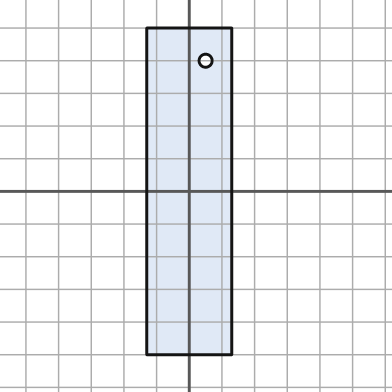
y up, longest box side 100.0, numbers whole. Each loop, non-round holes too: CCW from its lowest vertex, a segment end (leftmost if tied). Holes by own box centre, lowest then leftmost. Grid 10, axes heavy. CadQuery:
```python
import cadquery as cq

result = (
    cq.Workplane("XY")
    .moveTo(-13.0, -50.0)
    .lineTo(13.0, -50.0)
    .lineTo(13.0, 50.0)
    .lineTo(-13.0, 50.0)
    .close()
    .moveTo(5.0, 40.0)
    .circle(2.0)
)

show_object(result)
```